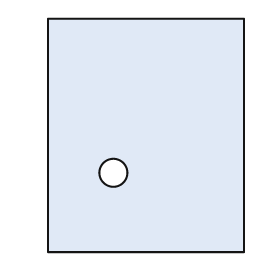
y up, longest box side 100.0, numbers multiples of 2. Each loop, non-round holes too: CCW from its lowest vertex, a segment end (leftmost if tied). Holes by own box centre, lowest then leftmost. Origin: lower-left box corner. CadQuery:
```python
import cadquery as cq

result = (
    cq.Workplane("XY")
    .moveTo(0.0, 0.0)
    .lineTo(84.0, 0.0)
    .lineTo(84.0, 100.0)
    .lineTo(0.0, 100.0)
    .close()
    .moveTo(28.0, 34.0)
    .circle(6.0)
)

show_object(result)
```